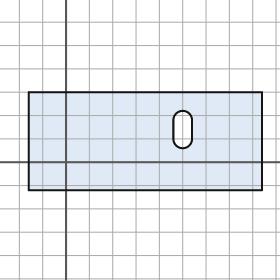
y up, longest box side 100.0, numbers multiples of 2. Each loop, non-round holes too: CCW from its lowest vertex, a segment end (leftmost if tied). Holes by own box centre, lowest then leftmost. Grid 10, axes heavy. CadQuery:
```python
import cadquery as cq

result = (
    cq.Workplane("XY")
    .moveTo(-16.0, -12.0)
    .lineTo(84.0, -12.0)
    .lineTo(84.0, 30.0)
    .lineTo(-16.0, 30.0)
    .close()
    .moveTo(46.0, 10.0)
    .threePointArc((50.0, 6.0), (54.0, 10.0))
    .lineTo(54.0, 18.0)
    .threePointArc((50.0, 22.0), (46.0, 18.0))
    .close()
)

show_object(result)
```